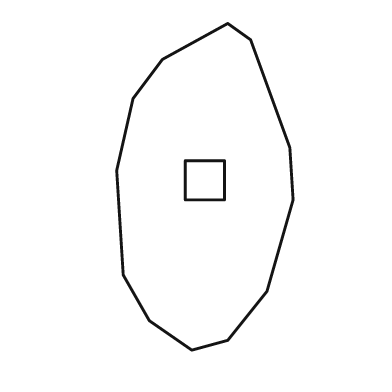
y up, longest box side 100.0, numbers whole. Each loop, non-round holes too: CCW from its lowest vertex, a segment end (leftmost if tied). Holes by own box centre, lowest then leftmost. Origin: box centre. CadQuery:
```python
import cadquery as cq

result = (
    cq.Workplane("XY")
    .moveTo(-4.0, -50.0)
    .lineTo(7.0, -47.0)
    .lineTo(19.0, -32.0)
    .lineTo(27.0, -4.0)
    .lineTo(26.0, 12.0)
    .lineTo(14.0, 45.0)
    .lineTo(7.0, 50.0)
    .lineTo(-13.0, 39.0)
    .lineTo(-22.0, 27.0)
    .lineTo(-27.0, 5.0)
    .lineTo(-25.0, -27.0)
    .lineTo(-17.0, -41.0)
    .close()
    .moveTo(-6.0, -4.0)
    .lineTo(6.0, -4.0)
    .lineTo(6.0, 8.0)
    .lineTo(-6.0, 8.0)
    .close()
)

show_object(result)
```